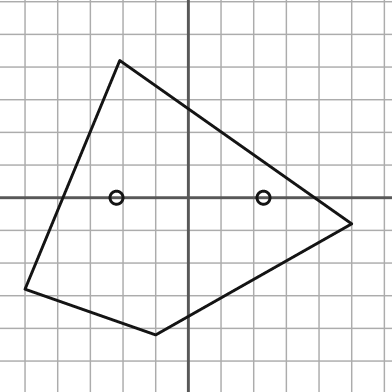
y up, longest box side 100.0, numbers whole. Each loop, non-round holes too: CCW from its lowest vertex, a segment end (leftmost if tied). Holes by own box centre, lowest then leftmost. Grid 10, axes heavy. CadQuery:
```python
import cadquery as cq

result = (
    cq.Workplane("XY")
    .moveTo(-10.0, -42.0)
    .lineTo(50.0, -8.0)
    .lineTo(-21.0, 42.0)
    .lineTo(-50.0, -28.0)
    .close()
    .moveTo(-22.0, 0.0)
    .circle(2.0)
    .moveTo(23.0, 0.0)
    .circle(2.0)
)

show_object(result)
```